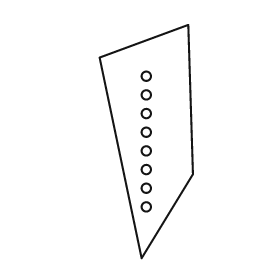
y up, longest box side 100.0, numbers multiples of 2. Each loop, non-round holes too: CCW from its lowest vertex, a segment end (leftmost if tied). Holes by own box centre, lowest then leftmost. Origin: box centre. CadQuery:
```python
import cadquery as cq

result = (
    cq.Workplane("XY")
    .moveTo(-2.0, -50.0)
    .lineTo(20.0, -14.0)
    .lineTo(18.0, 50.0)
    .lineTo(-20.0, 36.0)
    .close()
    .moveTo(0.0, -28.0)
    .circle(2.0)
    .moveTo(0.0, -20.0)
    .circle(2.0)
    .moveTo(0.0, -12.0)
    .circle(2.0)
    .moveTo(0.0, -4.0)
    .circle(2.0)
    .moveTo(0.0, 4.0)
    .circle(2.0)
    .moveTo(0.0, 12.0)
    .circle(2.0)
    .moveTo(0.0, 20.0)
    .circle(2.0)
    .moveTo(0.0, 28.0)
    .circle(2.0)
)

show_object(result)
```